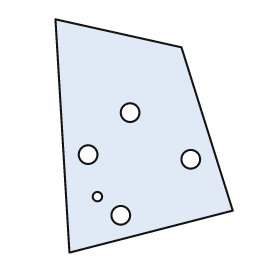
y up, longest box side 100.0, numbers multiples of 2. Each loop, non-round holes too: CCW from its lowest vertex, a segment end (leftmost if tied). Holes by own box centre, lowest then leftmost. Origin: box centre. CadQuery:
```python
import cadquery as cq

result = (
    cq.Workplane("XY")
    .moveTo(-32.0, -50.0)
    .lineTo(38.0, -32.0)
    .lineTo(16.0, 38.0)
    .lineTo(-38.0, 50.0)
    .close()
    .moveTo(-10.0, -34.0)
    .circle(4.0)
    .moveTo(-20.0, -26.0)
    .circle(2.0)
    .moveTo(20.0, -10.0)
    .circle(4.0)
    .moveTo(-24.0, -8.0)
    .circle(4.0)
    .moveTo(-6.0, 10.0)
    .circle(4.0)
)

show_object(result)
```